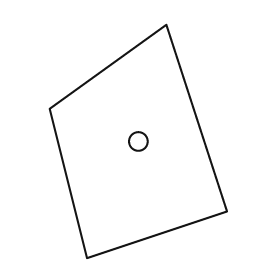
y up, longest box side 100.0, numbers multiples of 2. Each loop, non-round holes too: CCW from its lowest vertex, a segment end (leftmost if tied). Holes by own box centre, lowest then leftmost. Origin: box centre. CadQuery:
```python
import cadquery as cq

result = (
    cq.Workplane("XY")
    .moveTo(-22.0, -50.0)
    .lineTo(38.0, -30.0)
    .lineTo(12.0, 50.0)
    .lineTo(-38.0, 14.0)
    .close()
    .moveTo(0.0, 0.0)
    .circle(4.0)
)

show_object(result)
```